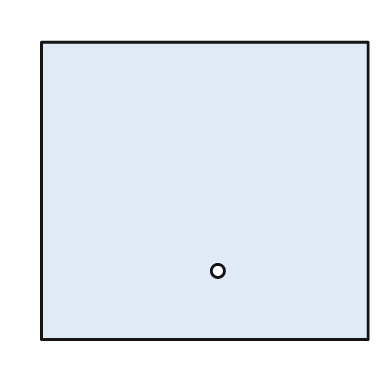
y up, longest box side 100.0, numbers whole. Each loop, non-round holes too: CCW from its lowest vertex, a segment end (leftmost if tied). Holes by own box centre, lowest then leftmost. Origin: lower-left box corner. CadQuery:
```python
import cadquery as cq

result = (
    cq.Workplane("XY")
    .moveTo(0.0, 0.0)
    .lineTo(100.0, 0.0)
    .lineTo(100.0, 91.0)
    .lineTo(0.0, 91.0)
    .close()
    .moveTo(54.0, 21.0)
    .circle(2.0)
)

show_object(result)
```